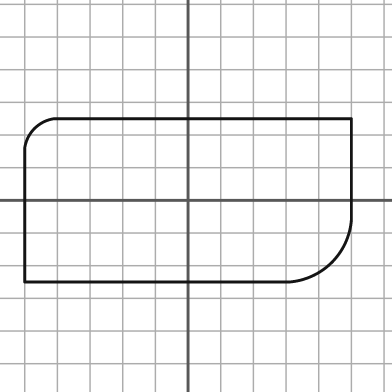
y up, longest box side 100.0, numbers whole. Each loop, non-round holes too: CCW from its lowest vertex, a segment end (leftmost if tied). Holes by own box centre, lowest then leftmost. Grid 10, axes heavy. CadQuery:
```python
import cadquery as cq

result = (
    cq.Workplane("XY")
    .moveTo(-50.0, -25.0)
    .lineTo(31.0, -25.0)
    .threePointArc((44.0, -19.0), (50.0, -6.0))
    .lineTo(50.0, 25.0)
    .lineTo(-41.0, 25.0)
    .threePointArc((-47.0, 22.0), (-50.0, 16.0))
    .close()
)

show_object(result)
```